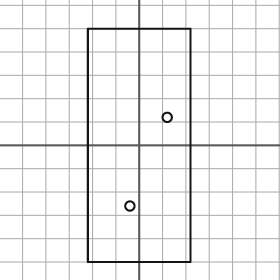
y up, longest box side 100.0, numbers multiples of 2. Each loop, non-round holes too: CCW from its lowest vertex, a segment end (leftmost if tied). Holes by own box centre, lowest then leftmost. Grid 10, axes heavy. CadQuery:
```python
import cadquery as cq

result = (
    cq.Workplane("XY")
    .moveTo(-22.0, -50.0)
    .lineTo(22.0, -50.0)
    .lineTo(22.0, 50.0)
    .lineTo(-22.0, 50.0)
    .close()
    .moveTo(-4.0, -26.0)
    .circle(2.0)
    .moveTo(12.0, 12.0)
    .circle(2.0)
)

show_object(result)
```